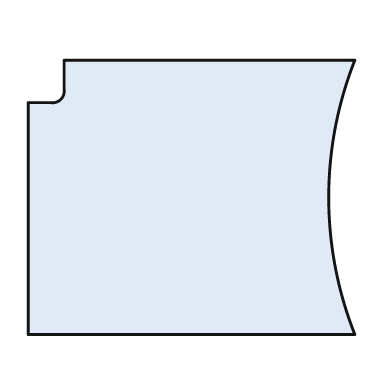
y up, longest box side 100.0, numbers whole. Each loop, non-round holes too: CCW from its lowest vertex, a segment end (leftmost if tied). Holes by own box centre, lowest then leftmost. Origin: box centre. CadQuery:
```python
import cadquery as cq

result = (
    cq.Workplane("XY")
    .moveTo(-50.0, -42.0)
    .lineTo(50.0, -42.0)
    .threePointArc((42.0, 0.0), (50.0, 42.0))
    .lineTo(-39.0, 42.0)
    .lineTo(-39.0, 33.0)
    .threePointArc((-40.0, 30.0), (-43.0, 29.0))
    .lineTo(-50.0, 29.0)
    .close()
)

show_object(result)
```